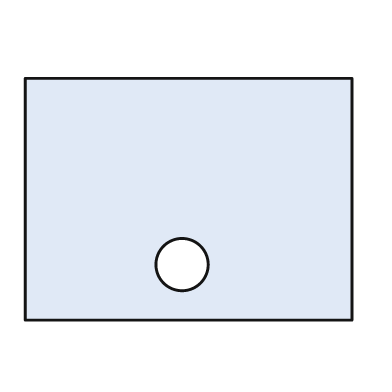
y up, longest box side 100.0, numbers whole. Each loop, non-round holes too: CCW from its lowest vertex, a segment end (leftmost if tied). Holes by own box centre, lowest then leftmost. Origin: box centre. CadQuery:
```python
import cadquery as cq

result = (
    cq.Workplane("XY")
    .moveTo(-50.0, -37.0)
    .lineTo(50.0, -37.0)
    .lineTo(50.0, 37.0)
    .lineTo(-50.0, 37.0)
    .close()
    .moveTo(-2.0, -20.0)
    .circle(8.0)
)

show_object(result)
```